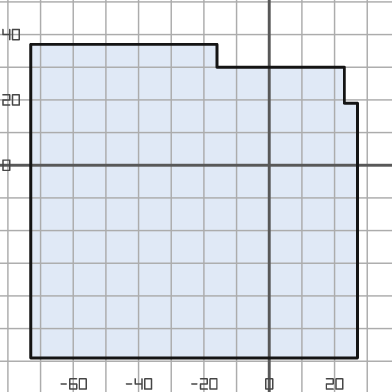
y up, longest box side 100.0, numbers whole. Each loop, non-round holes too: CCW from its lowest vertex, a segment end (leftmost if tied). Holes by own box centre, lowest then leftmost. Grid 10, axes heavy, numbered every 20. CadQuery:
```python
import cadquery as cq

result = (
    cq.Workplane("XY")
    .moveTo(-73.0, -59.0)
    .lineTo(27.0, -59.0)
    .lineTo(27.0, 19.0)
    .lineTo(23.0, 19.0)
    .lineTo(23.0, 30.0)
    .lineTo(-16.0, 30.0)
    .lineTo(-16.0, 37.0)
    .lineTo(-73.0, 37.0)
    .close()
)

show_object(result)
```